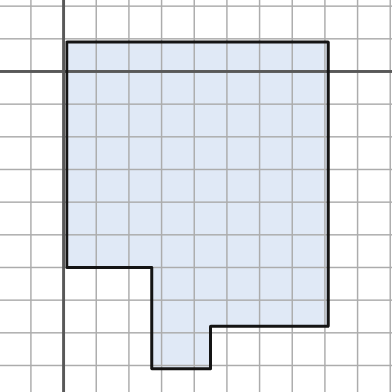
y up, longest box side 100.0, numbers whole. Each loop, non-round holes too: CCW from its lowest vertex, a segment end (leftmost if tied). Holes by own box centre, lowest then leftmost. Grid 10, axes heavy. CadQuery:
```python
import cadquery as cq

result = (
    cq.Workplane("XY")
    .moveTo(27.0, -91.0)
    .lineTo(45.0, -91.0)
    .lineTo(45.0, -78.0)
    .lineTo(81.0, -78.0)
    .lineTo(81.0, 9.0)
    .lineTo(1.0, 9.0)
    .lineTo(1.0, -60.0)
    .lineTo(27.0, -60.0)
    .close()
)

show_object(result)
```